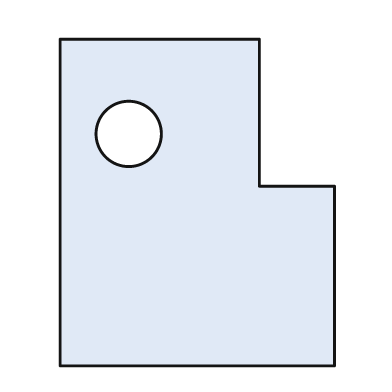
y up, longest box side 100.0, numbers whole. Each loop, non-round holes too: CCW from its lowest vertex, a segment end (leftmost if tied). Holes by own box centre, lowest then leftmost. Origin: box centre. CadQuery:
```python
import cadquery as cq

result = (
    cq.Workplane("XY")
    .moveTo(-42.0, -50.0)
    .lineTo(42.0, -50.0)
    .lineTo(42.0, 5.0)
    .lineTo(19.0, 5.0)
    .lineTo(19.0, 50.0)
    .lineTo(-42.0, 50.0)
    .close()
    .moveTo(-21.0, 21.0)
    .circle(10.0)
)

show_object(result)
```